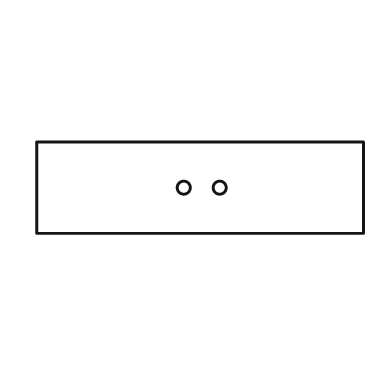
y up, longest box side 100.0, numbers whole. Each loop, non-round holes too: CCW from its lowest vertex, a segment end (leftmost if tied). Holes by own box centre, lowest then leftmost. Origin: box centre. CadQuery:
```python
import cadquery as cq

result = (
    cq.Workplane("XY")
    .moveTo(-50.0, -14.0)
    .lineTo(50.0, -14.0)
    .lineTo(50.0, 14.0)
    .lineTo(-50.0, 14.0)
    .close()
    .moveTo(-5.0, 0.0)
    .circle(2.0)
    .moveTo(6.0, 0.0)
    .circle(2.0)
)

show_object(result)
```